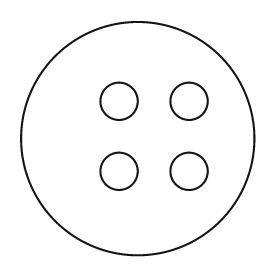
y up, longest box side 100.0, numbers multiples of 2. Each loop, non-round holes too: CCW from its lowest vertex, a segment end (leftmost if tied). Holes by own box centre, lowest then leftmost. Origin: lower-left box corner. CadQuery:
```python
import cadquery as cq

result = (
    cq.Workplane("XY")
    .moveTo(50.0, 50.0)
    .circle(50.0)
    .moveTo(42.0, 36.0)
    .circle(8.0)
    .moveTo(72.0, 36.0)
    .circle(8.0)
    .moveTo(42.0, 66.0)
    .circle(8.0)
    .moveTo(72.0, 66.0)
    .circle(8.0)
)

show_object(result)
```